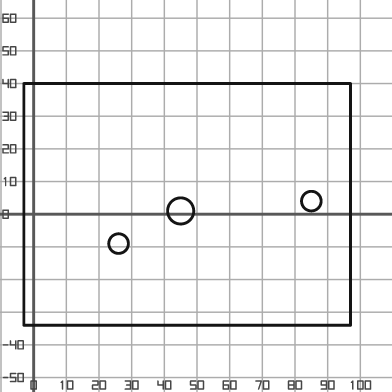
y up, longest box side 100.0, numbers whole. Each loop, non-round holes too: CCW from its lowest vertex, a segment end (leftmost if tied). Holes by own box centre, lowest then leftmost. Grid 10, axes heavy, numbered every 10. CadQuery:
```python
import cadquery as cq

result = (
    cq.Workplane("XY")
    .moveTo(-3.0, -34.0)
    .lineTo(97.0, -34.0)
    .lineTo(97.0, 40.0)
    .lineTo(-3.0, 40.0)
    .close()
    .moveTo(26.0, -9.0)
    .circle(3.0)
    .moveTo(45.0, 1.0)
    .circle(4.0)
    .moveTo(85.0, 4.0)
    .circle(3.0)
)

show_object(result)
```